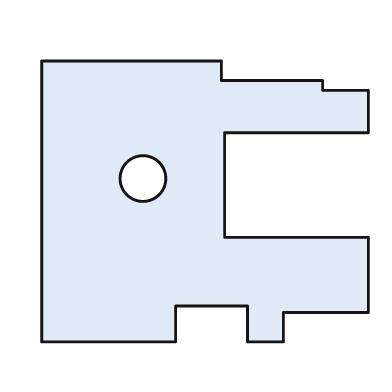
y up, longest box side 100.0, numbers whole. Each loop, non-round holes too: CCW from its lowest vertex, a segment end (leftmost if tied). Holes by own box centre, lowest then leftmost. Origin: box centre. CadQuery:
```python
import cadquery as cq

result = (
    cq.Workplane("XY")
    .moveTo(-50.0, -43.0)
    .lineTo(-9.0, -43.0)
    .lineTo(-9.0, -32.0)
    .lineTo(13.0, -32.0)
    .lineTo(13.0, -43.0)
    .lineTo(24.0, -43.0)
    .lineTo(24.0, -34.0)
    .lineTo(50.0, -34.0)
    .lineTo(50.0, -11.0)
    .lineTo(6.0, -11.0)
    .lineTo(6.0, 21.0)
    .lineTo(50.0, 21.0)
    .lineTo(50.0, 34.0)
    .lineTo(36.0, 34.0)
    .lineTo(36.0, 37.0)
    .lineTo(5.0, 37.0)
    .lineTo(5.0, 43.0)
    .lineTo(-50.0, 43.0)
    .close()
    .moveTo(-19.0, 7.0)
    .circle(7.0)
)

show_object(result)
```